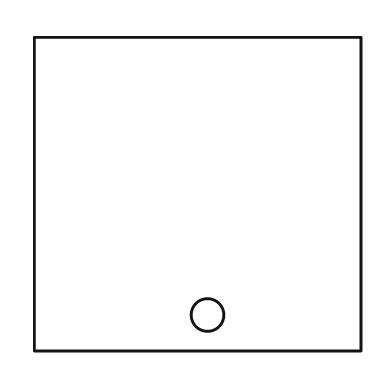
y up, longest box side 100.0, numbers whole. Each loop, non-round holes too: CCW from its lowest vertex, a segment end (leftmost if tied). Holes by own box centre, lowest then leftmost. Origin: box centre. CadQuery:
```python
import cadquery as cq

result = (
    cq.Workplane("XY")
    .moveTo(-50.0, -48.0)
    .lineTo(50.0, -48.0)
    .lineTo(50.0, 48.0)
    .lineTo(-50.0, 48.0)
    .close()
    .moveTo(3.0, -37.0)
    .circle(5.0)
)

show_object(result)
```